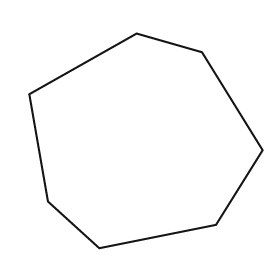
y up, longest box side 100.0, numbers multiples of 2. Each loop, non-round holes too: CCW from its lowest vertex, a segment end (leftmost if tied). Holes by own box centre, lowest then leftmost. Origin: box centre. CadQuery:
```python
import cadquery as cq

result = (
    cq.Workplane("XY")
    .moveTo(-20.0, -46.0)
    .lineTo(30.0, -36.0)
    .lineTo(50.0, -4.0)
    .lineTo(24.0, 38.0)
    .lineTo(-4.0, 46.0)
    .lineTo(-50.0, 20.0)
    .lineTo(-42.0, -26.0)
    .close()
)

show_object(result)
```